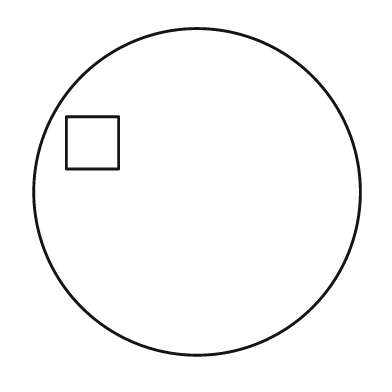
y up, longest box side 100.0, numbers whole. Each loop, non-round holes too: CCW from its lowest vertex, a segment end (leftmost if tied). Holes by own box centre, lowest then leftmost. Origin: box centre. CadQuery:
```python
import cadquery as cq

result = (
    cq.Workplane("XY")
    .moveTo(0.0, 0.0)
    .circle(50.0)
    .moveTo(-40.0, 7.0)
    .lineTo(-24.0, 7.0)
    .lineTo(-24.0, 23.0)
    .lineTo(-40.0, 23.0)
    .close()
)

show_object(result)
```